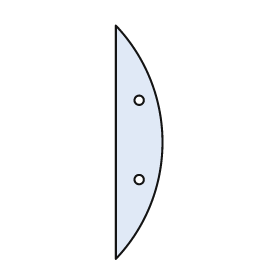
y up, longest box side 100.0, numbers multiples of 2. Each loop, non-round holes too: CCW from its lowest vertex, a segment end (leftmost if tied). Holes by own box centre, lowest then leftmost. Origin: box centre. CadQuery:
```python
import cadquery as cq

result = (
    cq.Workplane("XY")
    .moveTo(-10.0, -50.0)
    .threePointArc((10.0, 0.0), (-10.0, 50.0))
    .close()
    .moveTo(0.0, -16.0)
    .circle(2.0)
    .moveTo(0.0, 18.0)
    .circle(2.0)
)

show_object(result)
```